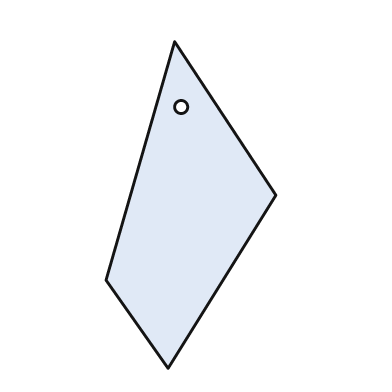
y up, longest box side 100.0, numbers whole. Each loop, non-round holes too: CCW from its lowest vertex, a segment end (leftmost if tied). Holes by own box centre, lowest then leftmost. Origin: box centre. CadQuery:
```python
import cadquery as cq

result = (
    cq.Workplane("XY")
    .moveTo(-7.0, -50.0)
    .lineTo(26.0, 3.0)
    .lineTo(-5.0, 50.0)
    .lineTo(-26.0, -23.0)
    .close()
    .moveTo(-3.0, 30.0)
    .circle(2.0)
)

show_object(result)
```